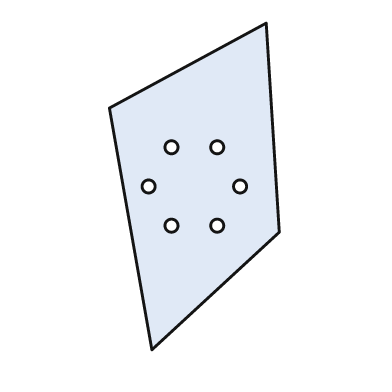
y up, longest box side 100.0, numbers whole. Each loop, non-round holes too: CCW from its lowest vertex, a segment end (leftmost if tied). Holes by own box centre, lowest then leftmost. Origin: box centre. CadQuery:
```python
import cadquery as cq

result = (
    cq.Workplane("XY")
    .moveTo(-13.0, -50.0)
    .lineTo(26.0, -14.0)
    .lineTo(22.0, 50.0)
    .lineTo(-26.0, 24.0)
    .close()
    .moveTo(-7.0, -12.0)
    .circle(2.0)
    .moveTo(7.0, -12.0)
    .circle(2.0)
    .moveTo(-14.0, 0.0)
    .circle(2.0)
    .moveTo(14.0, 0.0)
    .circle(2.0)
    .moveTo(-7.0, 12.0)
    .circle(2.0)
    .moveTo(7.0, 12.0)
    .circle(2.0)
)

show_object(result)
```